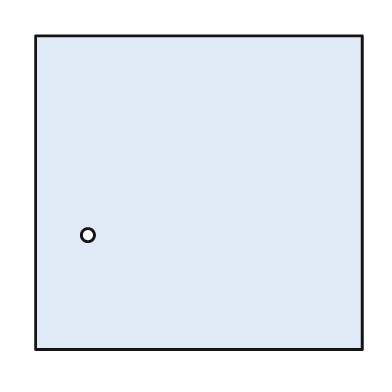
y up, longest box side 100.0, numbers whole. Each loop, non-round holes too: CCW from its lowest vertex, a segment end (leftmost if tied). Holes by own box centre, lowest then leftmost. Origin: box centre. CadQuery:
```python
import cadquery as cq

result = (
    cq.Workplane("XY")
    .moveTo(-50.0, -48.0)
    .lineTo(50.0, -48.0)
    .lineTo(50.0, 48.0)
    .lineTo(-50.0, 48.0)
    .close()
    .moveTo(-34.0, -13.0)
    .circle(2.0)
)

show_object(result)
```